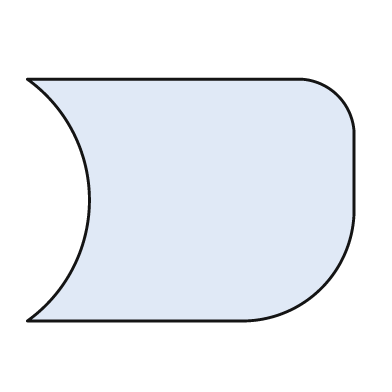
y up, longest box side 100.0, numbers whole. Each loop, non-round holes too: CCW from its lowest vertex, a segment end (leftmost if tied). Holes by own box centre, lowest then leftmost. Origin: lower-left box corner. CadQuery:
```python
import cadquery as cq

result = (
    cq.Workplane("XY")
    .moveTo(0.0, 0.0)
    .lineTo(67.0, 0.0)
    .threePointArc((90.0, 10.0), (100.0, 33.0))
    .lineTo(100.0, 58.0)
    .threePointArc((95.0, 69.0), (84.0, 74.0))
    .lineTo(0.0, 74.0)
    .threePointArc((19.0, 37.0), (0.0, 0.0))
    .close()
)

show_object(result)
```